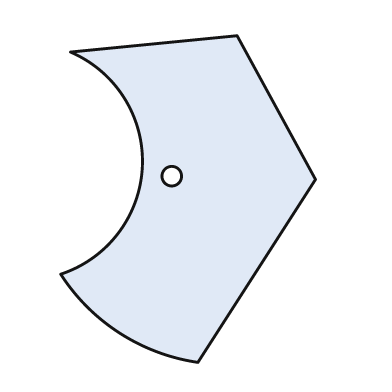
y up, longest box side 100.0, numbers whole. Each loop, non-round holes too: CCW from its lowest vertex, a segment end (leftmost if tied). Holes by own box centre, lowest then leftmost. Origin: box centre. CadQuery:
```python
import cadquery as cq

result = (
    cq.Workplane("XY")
    .moveTo(3.0, -50.0)
    .lineTo(39.0, 6.0)
    .lineTo(15.0, 50.0)
    .lineTo(-36.0, 45.0)
    .threePointArc((-14.0, 10.0), (-39.0, -23.0))
    .threePointArc((-21.0, -41.0), (3.0, -50.0))
    .close()
    .moveTo(-5.0, 7.0)
    .circle(3.0)
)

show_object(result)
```